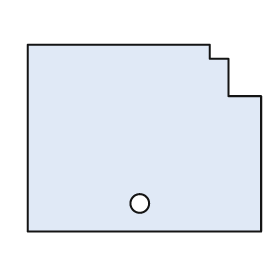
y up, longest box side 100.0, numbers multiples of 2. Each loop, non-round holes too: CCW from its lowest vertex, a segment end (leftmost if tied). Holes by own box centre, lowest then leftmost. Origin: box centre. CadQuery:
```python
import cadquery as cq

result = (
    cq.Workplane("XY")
    .moveTo(-50.0, -40.0)
    .lineTo(50.0, -40.0)
    .lineTo(50.0, 18.0)
    .lineTo(36.0, 18.0)
    .lineTo(36.0, 34.0)
    .lineTo(28.0, 34.0)
    .lineTo(28.0, 40.0)
    .lineTo(-50.0, 40.0)
    .close()
    .moveTo(-2.0, -28.0)
    .circle(4.0)
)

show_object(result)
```